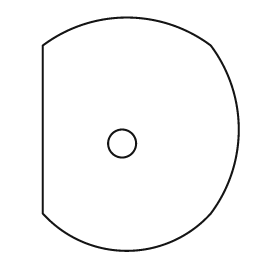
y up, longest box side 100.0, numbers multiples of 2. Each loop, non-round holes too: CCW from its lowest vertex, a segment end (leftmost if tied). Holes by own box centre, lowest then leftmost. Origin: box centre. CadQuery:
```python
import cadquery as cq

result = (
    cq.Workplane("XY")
    .moveTo(-42.0, -34.0)
    .threePointArc((-6.0, -50.0), (30.0, -34.0))
    .threePointArc((42.0, 2.0), (30.0, 38.0))
    .threePointArc((-6.0, 50.0), (-42.0, 38.0))
    .close()
    .moveTo(-8.0, -4.0)
    .circle(6.0)
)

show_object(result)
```